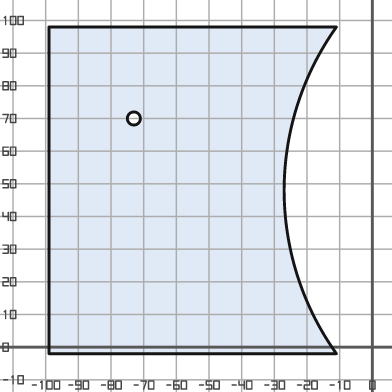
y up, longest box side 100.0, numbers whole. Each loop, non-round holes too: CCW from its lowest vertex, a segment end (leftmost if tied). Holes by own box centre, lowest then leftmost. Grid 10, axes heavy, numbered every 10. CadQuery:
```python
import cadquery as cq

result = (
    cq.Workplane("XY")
    .moveTo(-99.0, -2.0)
    .lineTo(-11.0, -2.0)
    .threePointArc((-27.0, 48.0), (-11.0, 98.0))
    .lineTo(-99.0, 98.0)
    .close()
    .moveTo(-73.0, 70.0)
    .circle(2.0)
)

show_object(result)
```